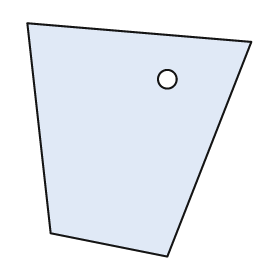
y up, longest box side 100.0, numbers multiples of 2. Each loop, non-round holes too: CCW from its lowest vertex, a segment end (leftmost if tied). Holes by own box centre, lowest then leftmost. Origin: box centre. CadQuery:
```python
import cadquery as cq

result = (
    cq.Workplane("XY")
    .moveTo(12.0, -50.0)
    .lineTo(48.0, 42.0)
    .lineTo(-48.0, 50.0)
    .lineTo(-38.0, -40.0)
    .close()
    .moveTo(12.0, 26.0)
    .circle(4.0)
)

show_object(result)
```